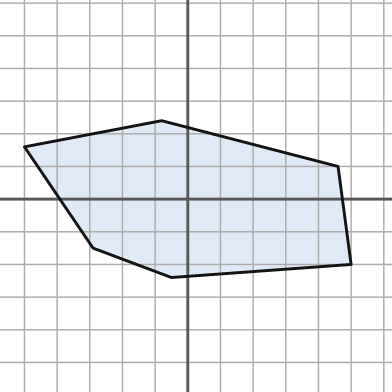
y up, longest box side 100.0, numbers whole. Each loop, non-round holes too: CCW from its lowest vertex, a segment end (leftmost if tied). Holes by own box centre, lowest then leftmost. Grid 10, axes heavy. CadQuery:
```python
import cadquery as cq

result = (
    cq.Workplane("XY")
    .moveTo(-5.0, -24.0)
    .lineTo(50.0, -20.0)
    .lineTo(46.0, 10.0)
    .lineTo(-8.0, 24.0)
    .lineTo(-50.0, 16.0)
    .lineTo(-29.0, -15.0)
    .close()
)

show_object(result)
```